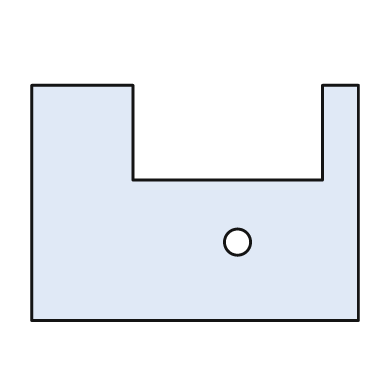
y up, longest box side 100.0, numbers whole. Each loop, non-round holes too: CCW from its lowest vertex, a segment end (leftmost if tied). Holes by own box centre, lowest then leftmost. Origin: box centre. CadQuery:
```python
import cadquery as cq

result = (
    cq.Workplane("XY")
    .moveTo(-50.0, -36.0)
    .lineTo(50.0, -36.0)
    .lineTo(50.0, 36.0)
    .lineTo(39.0, 36.0)
    .lineTo(39.0, 7.0)
    .lineTo(-19.0, 7.0)
    .lineTo(-19.0, 36.0)
    .lineTo(-50.0, 36.0)
    .close()
    .moveTo(13.0, -12.0)
    .circle(4.0)
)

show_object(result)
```